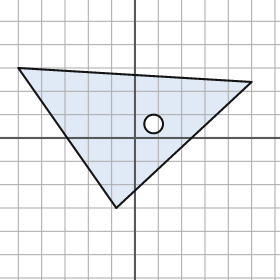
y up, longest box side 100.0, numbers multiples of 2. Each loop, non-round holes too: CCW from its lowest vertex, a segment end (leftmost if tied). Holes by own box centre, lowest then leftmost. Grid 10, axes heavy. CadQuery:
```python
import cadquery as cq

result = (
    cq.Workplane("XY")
    .moveTo(-8.0, -30.0)
    .lineTo(50.0, 24.0)
    .lineTo(-50.0, 30.0)
    .close()
    .moveTo(8.0, 6.0)
    .circle(4.0)
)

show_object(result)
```